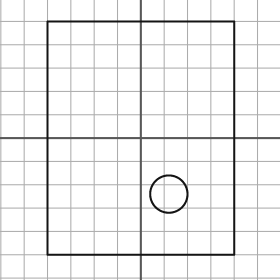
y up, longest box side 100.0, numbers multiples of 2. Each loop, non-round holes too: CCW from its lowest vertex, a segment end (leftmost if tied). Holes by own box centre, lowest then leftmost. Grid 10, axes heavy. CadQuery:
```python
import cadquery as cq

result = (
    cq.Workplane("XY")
    .moveTo(-40.0, -50.0)
    .lineTo(40.0, -50.0)
    .lineTo(40.0, 50.0)
    .lineTo(-40.0, 50.0)
    .close()
    .moveTo(12.0, -24.0)
    .circle(8.0)
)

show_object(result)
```